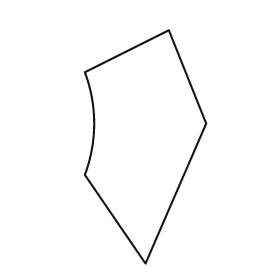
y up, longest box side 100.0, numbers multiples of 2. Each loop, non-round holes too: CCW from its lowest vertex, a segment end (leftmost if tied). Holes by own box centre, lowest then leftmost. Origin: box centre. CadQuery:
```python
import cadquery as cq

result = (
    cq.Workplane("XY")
    .moveTo(0.0, -50.0)
    .lineTo(26.0, 10.0)
    .lineTo(10.0, 50.0)
    .lineTo(-26.0, 32.0)
    .threePointArc((-22.0, 10.0), (-26.0, -12.0))
    .close()
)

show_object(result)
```